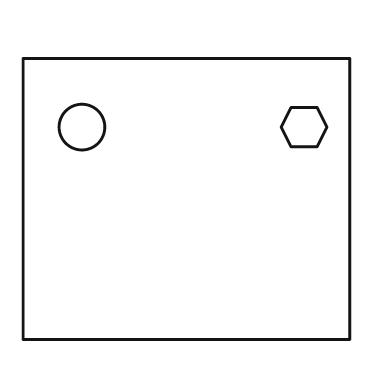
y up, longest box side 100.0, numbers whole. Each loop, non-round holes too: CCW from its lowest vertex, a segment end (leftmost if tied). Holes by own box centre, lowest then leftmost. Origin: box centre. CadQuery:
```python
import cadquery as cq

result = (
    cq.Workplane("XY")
    .moveTo(-50.0, -43.0)
    .lineTo(50.0, -43.0)
    .lineTo(50.0, 43.0)
    .lineTo(-50.0, 43.0)
    .close()
    .moveTo(-32.0, 22.0)
    .circle(7.0)
    .moveTo(32.0, 16.0)
    .lineTo(40.0, 16.0)
    .lineTo(43.0, 22.0)
    .lineTo(40.0, 28.0)
    .lineTo(32.0, 28.0)
    .lineTo(29.0, 22.0)
    .close()
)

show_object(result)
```